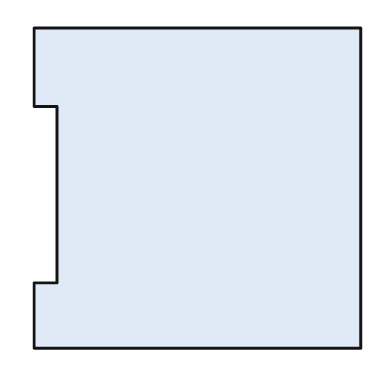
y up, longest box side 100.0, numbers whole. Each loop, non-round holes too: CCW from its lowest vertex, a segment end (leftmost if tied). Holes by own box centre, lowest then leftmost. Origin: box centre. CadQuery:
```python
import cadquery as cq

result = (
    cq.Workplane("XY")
    .moveTo(-50.0, -49.0)
    .lineTo(50.0, -49.0)
    .lineTo(50.0, 49.0)
    .lineTo(-50.0, 49.0)
    .lineTo(-50.0, 25.0)
    .lineTo(-43.0, 25.0)
    .lineTo(-43.0, -29.0)
    .lineTo(-50.0, -29.0)
    .close()
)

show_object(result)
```